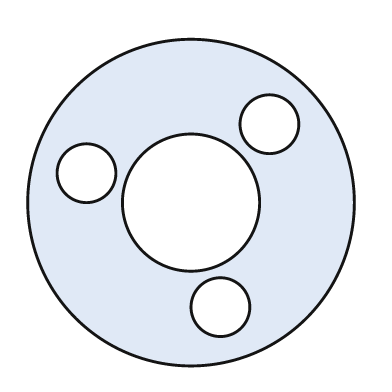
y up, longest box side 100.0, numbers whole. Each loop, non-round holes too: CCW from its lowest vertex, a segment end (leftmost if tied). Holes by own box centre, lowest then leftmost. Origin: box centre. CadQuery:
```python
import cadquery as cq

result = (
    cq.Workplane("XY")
    .moveTo(0.0, 0.0)
    .circle(50.0)
    .moveTo(9.0, -32.0)
    .circle(9.0)
    .moveTo(0.0, 0.0)
    .circle(21.0)
    .moveTo(-32.0, 9.0)
    .circle(9.0)
    .moveTo(24.0, 24.0)
    .circle(9.0)
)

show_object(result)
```